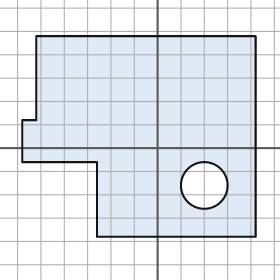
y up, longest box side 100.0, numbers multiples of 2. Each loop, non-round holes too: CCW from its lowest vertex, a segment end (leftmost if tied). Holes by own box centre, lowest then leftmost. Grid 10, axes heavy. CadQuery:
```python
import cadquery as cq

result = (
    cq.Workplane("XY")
    .moveTo(-26.0, -38.0)
    .lineTo(42.0, -38.0)
    .lineTo(42.0, 48.0)
    .lineTo(-52.0, 48.0)
    .lineTo(-52.0, 12.0)
    .lineTo(-58.0, 12.0)
    .lineTo(-58.0, -6.0)
    .lineTo(-26.0, -6.0)
    .close()
    .moveTo(20.0, -16.0)
    .circle(10.0)
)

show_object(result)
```